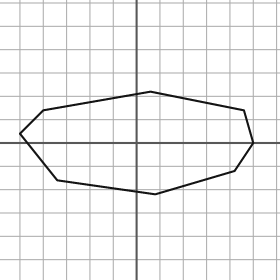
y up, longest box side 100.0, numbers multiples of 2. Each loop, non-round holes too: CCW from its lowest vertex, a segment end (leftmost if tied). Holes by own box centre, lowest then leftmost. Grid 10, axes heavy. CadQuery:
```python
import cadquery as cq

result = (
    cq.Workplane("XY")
    .moveTo(8.0, -22.0)
    .lineTo(42.0, -12.0)
    .lineTo(50.0, 0.0)
    .lineTo(46.0, 14.0)
    .lineTo(6.0, 22.0)
    .lineTo(-40.0, 14.0)
    .lineTo(-50.0, 4.0)
    .lineTo(-34.0, -16.0)
    .close()
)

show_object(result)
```